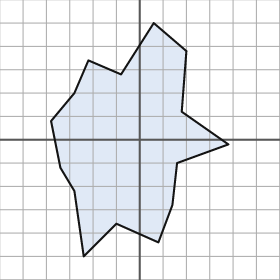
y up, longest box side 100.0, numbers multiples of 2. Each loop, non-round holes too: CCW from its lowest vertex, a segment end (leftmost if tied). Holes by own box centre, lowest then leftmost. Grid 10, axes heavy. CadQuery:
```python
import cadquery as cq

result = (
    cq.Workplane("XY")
    .moveTo(-24.0, -50.0)
    .lineTo(-10.0, -36.0)
    .lineTo(8.0, -44.0)
    .lineTo(14.0, -28.0)
    .lineTo(16.0, -10.0)
    .lineTo(38.0, -2.0)
    .lineTo(18.0, 12.0)
    .lineTo(20.0, 38.0)
    .lineTo(6.0, 50.0)
    .lineTo(-8.0, 28.0)
    .lineTo(-22.0, 34.0)
    .lineTo(-28.0, 20.0)
    .lineTo(-38.0, 8.0)
    .lineTo(-34.0, -12.0)
    .lineTo(-28.0, -22.0)
    .close()
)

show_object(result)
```